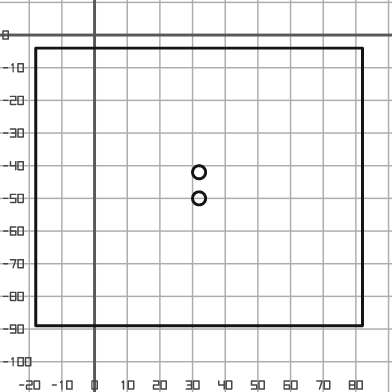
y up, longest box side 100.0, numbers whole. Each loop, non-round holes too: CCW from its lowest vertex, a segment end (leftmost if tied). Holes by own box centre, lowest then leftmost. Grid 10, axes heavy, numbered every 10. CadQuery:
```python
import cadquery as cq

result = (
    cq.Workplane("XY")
    .moveTo(-18.0, -89.0)
    .lineTo(82.0, -89.0)
    .lineTo(82.0, -4.0)
    .lineTo(-18.0, -4.0)
    .close()
    .moveTo(32.0, -50.0)
    .circle(2.0)
    .moveTo(32.0, -42.0)
    .circle(2.0)
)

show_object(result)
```